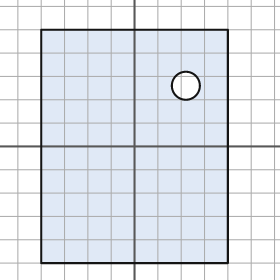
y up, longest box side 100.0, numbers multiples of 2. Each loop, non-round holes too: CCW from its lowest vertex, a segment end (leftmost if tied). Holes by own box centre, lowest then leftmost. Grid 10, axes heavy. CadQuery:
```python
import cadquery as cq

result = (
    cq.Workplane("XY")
    .moveTo(-40.0, -50.0)
    .lineTo(40.0, -50.0)
    .lineTo(40.0, 50.0)
    .lineTo(-40.0, 50.0)
    .close()
    .moveTo(22.0, 26.0)
    .circle(6.0)
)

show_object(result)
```